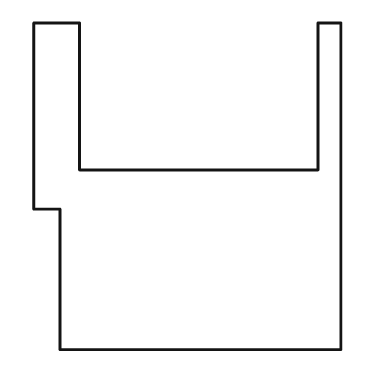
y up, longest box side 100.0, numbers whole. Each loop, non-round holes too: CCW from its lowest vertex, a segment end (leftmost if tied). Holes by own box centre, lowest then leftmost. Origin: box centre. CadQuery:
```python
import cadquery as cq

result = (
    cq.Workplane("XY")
    .moveTo(-39.0, -50.0)
    .lineTo(47.0, -50.0)
    .lineTo(47.0, 50.0)
    .lineTo(40.0, 50.0)
    .lineTo(40.0, 5.0)
    .lineTo(-33.0, 5.0)
    .lineTo(-33.0, 50.0)
    .lineTo(-47.0, 50.0)
    .lineTo(-47.0, -7.0)
    .lineTo(-39.0, -7.0)
    .close()
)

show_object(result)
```